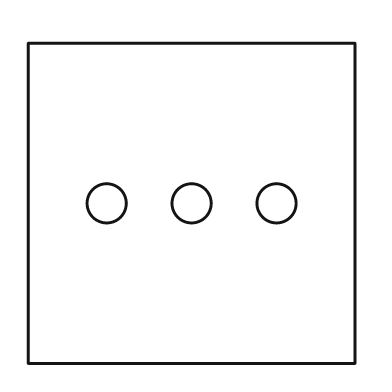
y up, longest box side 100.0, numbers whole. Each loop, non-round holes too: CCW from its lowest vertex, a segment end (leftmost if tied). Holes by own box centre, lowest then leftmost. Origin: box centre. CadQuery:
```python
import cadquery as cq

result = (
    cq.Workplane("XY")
    .moveTo(-50.0, -49.0)
    .lineTo(50.0, -49.0)
    .lineTo(50.0, 49.0)
    .lineTo(-50.0, 49.0)
    .close()
    .moveTo(-26.0, 0.0)
    .circle(6.0)
    .moveTo(0.0, 0.0)
    .circle(6.0)
    .moveTo(26.0, 0.0)
    .circle(6.0)
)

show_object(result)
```